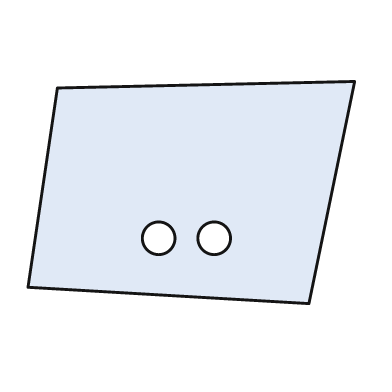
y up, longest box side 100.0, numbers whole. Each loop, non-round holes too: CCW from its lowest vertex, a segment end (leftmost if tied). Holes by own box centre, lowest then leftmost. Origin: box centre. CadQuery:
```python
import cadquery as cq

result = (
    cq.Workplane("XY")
    .moveTo(36.0, -34.0)
    .lineTo(50.0, 34.0)
    .lineTo(-41.0, 32.0)
    .lineTo(-50.0, -29.0)
    .close()
    .moveTo(-10.0, -14.0)
    .circle(5.0)
    .moveTo(7.0, -14.0)
    .circle(5.0)
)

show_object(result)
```